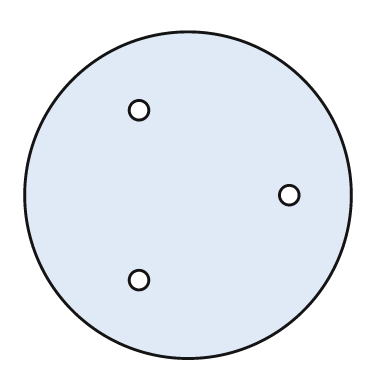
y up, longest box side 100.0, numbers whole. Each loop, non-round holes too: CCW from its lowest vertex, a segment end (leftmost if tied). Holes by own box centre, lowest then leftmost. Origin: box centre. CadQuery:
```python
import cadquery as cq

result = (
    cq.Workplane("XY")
    .moveTo(0.0, 0.0)
    .circle(50.0)
    .moveTo(-15.0, -26.0)
    .circle(3.0)
    .moveTo(31.0, 0.0)
    .circle(3.0)
    .moveTo(-15.0, 26.0)
    .circle(3.0)
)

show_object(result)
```